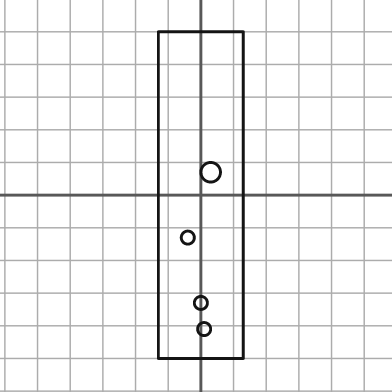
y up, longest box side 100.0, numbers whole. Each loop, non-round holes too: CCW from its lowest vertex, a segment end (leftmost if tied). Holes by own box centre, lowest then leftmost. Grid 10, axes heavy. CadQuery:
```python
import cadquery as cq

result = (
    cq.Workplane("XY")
    .moveTo(-13.0, -50.0)
    .lineTo(13.0, -50.0)
    .lineTo(13.0, 50.0)
    .lineTo(-13.0, 50.0)
    .close()
    .moveTo(1.0, -41.0)
    .circle(2.0)
    .moveTo(0.0, -33.0)
    .circle(2.0)
    .moveTo(-4.0, -13.0)
    .circle(2.0)
    .moveTo(3.0, 7.0)
    .circle(3.0)
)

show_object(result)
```